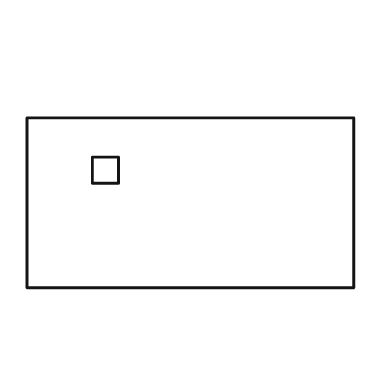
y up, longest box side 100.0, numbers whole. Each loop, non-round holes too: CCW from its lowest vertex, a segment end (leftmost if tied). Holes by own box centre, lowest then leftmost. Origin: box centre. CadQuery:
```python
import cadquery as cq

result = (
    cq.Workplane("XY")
    .moveTo(-50.0, -26.0)
    .lineTo(50.0, -26.0)
    .lineTo(50.0, 26.0)
    .lineTo(-50.0, 26.0)
    .close()
    .moveTo(-30.0, 6.0)
    .lineTo(-22.0, 6.0)
    .lineTo(-22.0, 14.0)
    .lineTo(-30.0, 14.0)
    .close()
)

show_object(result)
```